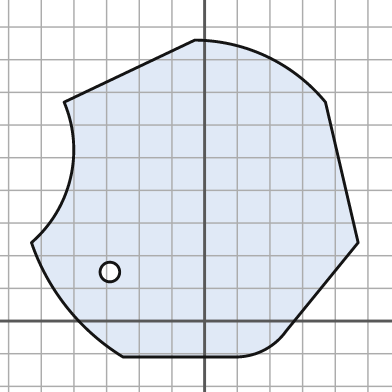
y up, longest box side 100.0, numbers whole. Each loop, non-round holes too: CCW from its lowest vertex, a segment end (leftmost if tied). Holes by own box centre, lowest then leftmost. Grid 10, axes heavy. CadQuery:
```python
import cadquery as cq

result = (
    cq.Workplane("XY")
    .moveTo(-25.0, -11.0)
    .lineTo(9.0, -11.0)
    .threePointArc((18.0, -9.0), (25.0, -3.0))
    .lineTo(47.0, 24.0)
    .lineTo(37.0, 67.0)
    .threePointArc((19.0, 81.0), (-3.0, 86.0))
    .lineTo(-43.0, 67.0)
    .threePointArc((-41.0, 44.0), (-53.0, 24.0))
    .threePointArc((-42.0, 4.0), (-25.0, -11.0))
    .close()
    .moveTo(-29.0, 15.0)
    .circle(3.0)
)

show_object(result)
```